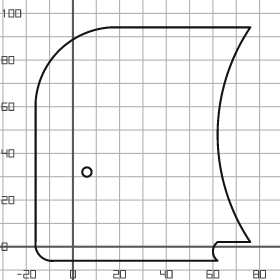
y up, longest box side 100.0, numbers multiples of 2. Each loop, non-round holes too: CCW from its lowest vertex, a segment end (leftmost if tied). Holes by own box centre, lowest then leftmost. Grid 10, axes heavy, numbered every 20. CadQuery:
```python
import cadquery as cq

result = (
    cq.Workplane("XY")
    .moveTo(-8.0, -6.0)
    .lineTo(62.0, -6.0)
    .threePointArc((60.0, -2.0), (62.0, 2.0))
    .lineTo(76.0, 2.0)
    .threePointArc((62.0, 48.0), (76.0, 94.0))
    .lineTo(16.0, 94.0)
    .threePointArc((-6.0, 84.0), (-16.0, 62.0))
    .lineTo(-16.0, 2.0)
    .threePointArc((-14.0, -4.0), (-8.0, -6.0))
    .close()
    .moveTo(6.0, 32.0)
    .circle(2.0)
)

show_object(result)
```